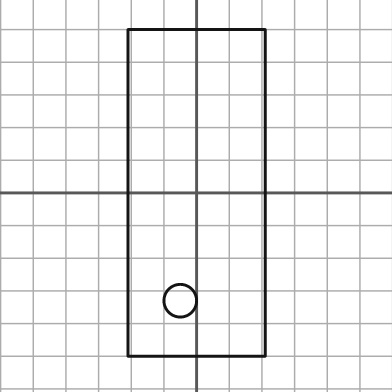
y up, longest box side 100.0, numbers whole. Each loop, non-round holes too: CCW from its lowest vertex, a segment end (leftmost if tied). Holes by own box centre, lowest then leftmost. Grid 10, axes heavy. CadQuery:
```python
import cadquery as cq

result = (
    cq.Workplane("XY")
    .moveTo(-21.0, -50.0)
    .lineTo(21.0, -50.0)
    .lineTo(21.0, 50.0)
    .lineTo(-21.0, 50.0)
    .close()
    .moveTo(-5.0, -33.0)
    .circle(5.0)
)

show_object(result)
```